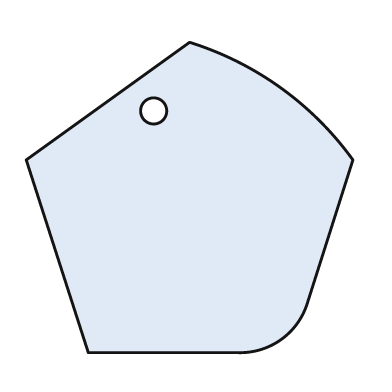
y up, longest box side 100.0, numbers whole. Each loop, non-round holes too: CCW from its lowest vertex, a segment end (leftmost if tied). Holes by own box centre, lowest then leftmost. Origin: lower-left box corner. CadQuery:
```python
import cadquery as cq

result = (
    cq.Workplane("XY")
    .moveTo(19.0, 0.0)
    .lineTo(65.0, 0.0)
    .threePointArc((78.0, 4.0), (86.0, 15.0))
    .lineTo(100.0, 59.0)
    .threePointArc((78.0, 81.0), (50.0, 95.0))
    .lineTo(0.0, 59.0)
    .close()
    .moveTo(39.0, 74.0)
    .circle(4.0)
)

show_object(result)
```